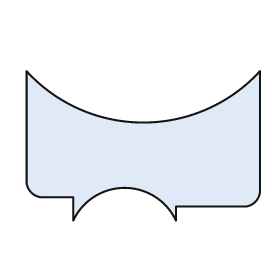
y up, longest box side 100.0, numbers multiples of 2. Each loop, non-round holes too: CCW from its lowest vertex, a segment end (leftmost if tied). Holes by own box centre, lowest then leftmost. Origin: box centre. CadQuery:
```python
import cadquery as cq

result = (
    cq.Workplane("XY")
    .moveTo(-30.0, -32.0)
    .threePointArc((-8.0, -18.0), (14.0, -32.0))
    .lineTo(14.0, -26.0)
    .lineTo(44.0, -26.0)
    .threePointArc((48.0, -24.0), (50.0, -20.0))
    .lineTo(50.0, 32.0)
    .threePointArc((0.0, 10.0), (-50.0, 32.0))
    .lineTo(-50.0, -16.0)
    .threePointArc((-48.0, -20.0), (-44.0, -22.0))
    .lineTo(-30.0, -22.0)
    .close()
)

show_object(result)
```